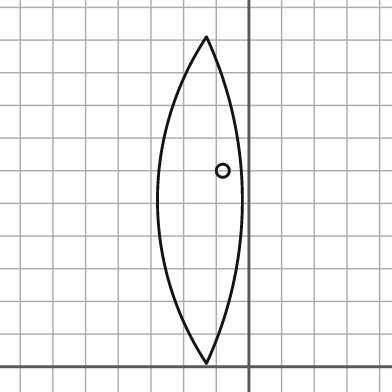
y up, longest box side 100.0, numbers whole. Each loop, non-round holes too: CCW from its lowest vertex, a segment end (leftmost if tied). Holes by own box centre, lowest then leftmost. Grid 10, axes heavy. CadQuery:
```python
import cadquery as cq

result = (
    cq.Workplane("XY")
    .moveTo(-13.0, 1.0)
    .threePointArc((-2.0, 51.0), (-13.0, 101.0))
    .threePointArc((-28.0, 51.0), (-13.0, 1.0))
    .close()
    .moveTo(-8.0, 60.0)
    .circle(2.0)
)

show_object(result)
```